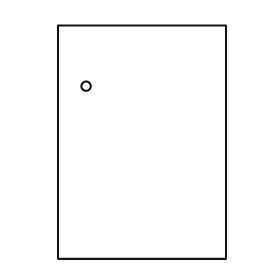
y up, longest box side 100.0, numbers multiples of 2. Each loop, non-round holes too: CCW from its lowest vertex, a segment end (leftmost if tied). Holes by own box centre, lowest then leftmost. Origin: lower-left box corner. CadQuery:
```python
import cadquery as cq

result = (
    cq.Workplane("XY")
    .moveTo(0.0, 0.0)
    .lineTo(72.0, 0.0)
    .lineTo(72.0, 100.0)
    .lineTo(0.0, 100.0)
    .close()
    .moveTo(12.0, 74.0)
    .circle(2.0)
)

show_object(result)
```